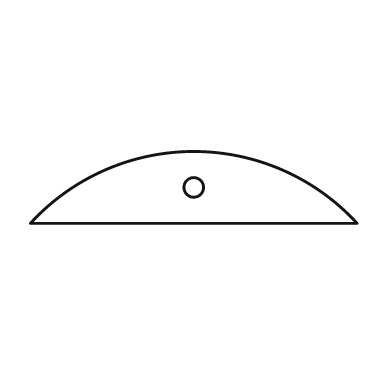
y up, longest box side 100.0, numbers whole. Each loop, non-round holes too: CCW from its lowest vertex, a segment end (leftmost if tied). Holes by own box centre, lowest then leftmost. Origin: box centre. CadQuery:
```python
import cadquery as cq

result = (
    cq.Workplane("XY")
    .moveTo(-50.0, -11.0)
    .lineTo(50.0, -11.0)
    .threePointArc((0.0, 11.0), (-50.0, -11.0))
    .close()
    .moveTo(0.0, 0.0)
    .circle(3.0)
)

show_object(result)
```